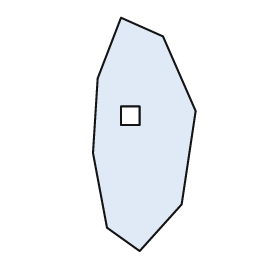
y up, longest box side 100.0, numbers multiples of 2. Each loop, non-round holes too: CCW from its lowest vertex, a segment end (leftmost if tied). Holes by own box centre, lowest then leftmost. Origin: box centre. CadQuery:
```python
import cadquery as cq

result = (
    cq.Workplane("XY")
    .moveTo(-2.0, -50.0)
    .lineTo(16.0, -30.0)
    .lineTo(22.0, 10.0)
    .lineTo(8.0, 42.0)
    .lineTo(-10.0, 50.0)
    .lineTo(-20.0, 24.0)
    .lineTo(-22.0, -8.0)
    .lineTo(-16.0, -40.0)
    .close()
    .moveTo(-10.0, 4.0)
    .lineTo(-2.0, 4.0)
    .lineTo(-2.0, 12.0)
    .lineTo(-10.0, 12.0)
    .close()
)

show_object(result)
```